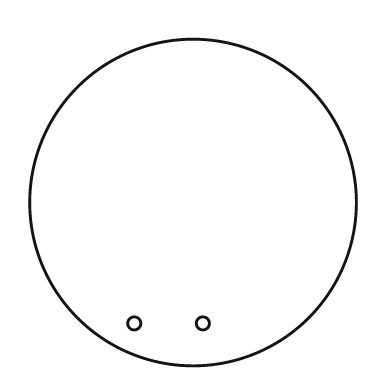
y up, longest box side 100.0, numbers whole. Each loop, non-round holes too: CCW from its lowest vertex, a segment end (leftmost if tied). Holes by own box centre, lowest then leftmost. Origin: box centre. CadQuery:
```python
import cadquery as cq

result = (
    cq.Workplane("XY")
    .moveTo(0.0, 0.0)
    .circle(50.0)
    .moveTo(-18.0, -37.0)
    .circle(2.0)
    .moveTo(3.0, -37.0)
    .circle(2.0)
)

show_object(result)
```